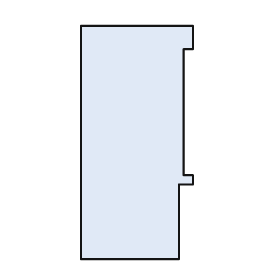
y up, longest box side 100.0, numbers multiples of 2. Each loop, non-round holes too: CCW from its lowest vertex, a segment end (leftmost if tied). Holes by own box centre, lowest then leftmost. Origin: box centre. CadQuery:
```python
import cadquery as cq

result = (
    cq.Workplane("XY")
    .moveTo(-24.0, -50.0)
    .lineTo(18.0, -50.0)
    .lineTo(18.0, -18.0)
    .lineTo(24.0, -18.0)
    .lineTo(24.0, -14.0)
    .lineTo(20.0, -14.0)
    .lineTo(20.0, 40.0)
    .lineTo(24.0, 40.0)
    .lineTo(24.0, 50.0)
    .lineTo(-24.0, 50.0)
    .close()
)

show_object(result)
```